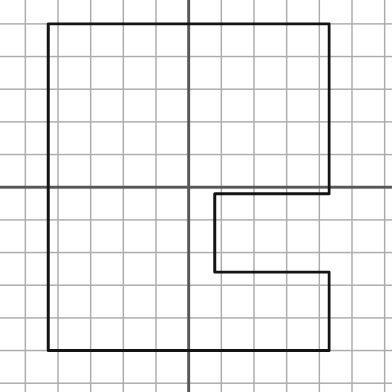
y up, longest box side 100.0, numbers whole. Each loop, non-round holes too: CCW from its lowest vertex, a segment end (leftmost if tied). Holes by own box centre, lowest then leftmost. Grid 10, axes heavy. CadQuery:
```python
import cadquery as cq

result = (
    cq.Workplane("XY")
    .moveTo(-43.0, -50.0)
    .lineTo(43.0, -50.0)
    .lineTo(43.0, -26.0)
    .lineTo(8.0, -26.0)
    .lineTo(8.0, -2.0)
    .lineTo(43.0, -2.0)
    .lineTo(43.0, 50.0)
    .lineTo(-43.0, 50.0)
    .close()
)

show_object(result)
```